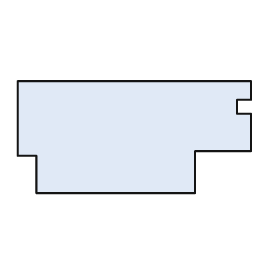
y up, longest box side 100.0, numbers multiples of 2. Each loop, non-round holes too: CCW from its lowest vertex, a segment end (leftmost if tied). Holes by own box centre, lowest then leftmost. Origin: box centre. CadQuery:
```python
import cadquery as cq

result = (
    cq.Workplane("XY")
    .moveTo(-42.0, -24.0)
    .lineTo(26.0, -24.0)
    .lineTo(26.0, -6.0)
    .lineTo(50.0, -6.0)
    .lineTo(50.0, 10.0)
    .lineTo(44.0, 10.0)
    .lineTo(44.0, 16.0)
    .lineTo(50.0, 16.0)
    .lineTo(50.0, 24.0)
    .lineTo(-50.0, 24.0)
    .lineTo(-50.0, -8.0)
    .lineTo(-42.0, -8.0)
    .close()
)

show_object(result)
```